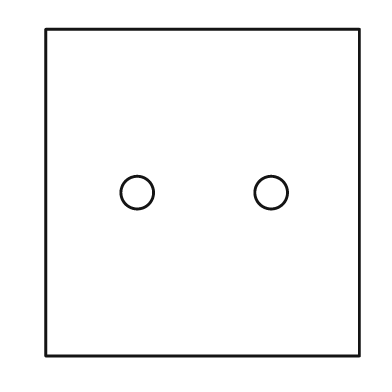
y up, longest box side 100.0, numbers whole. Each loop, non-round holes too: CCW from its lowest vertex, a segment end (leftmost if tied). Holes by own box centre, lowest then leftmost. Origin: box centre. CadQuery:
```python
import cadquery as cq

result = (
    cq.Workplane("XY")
    .moveTo(-48.0, -50.0)
    .lineTo(48.0, -50.0)
    .lineTo(48.0, 50.0)
    .lineTo(-48.0, 50.0)
    .close()
    .moveTo(-20.0, 0.0)
    .circle(5.0)
    .moveTo(21.0, 0.0)
    .circle(5.0)
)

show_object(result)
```